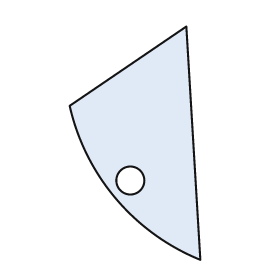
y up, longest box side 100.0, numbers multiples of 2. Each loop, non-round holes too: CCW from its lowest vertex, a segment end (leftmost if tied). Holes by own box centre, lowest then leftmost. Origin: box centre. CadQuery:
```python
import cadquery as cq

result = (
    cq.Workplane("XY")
    .moveTo(28.0, -50.0)
    .lineTo(22.0, 50.0)
    .lineTo(-28.0, 16.0)
    .threePointArc((-8.0, -24.0), (28.0, -50.0))
    .close()
    .moveTo(-2.0, -16.0)
    .circle(6.0)
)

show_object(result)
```